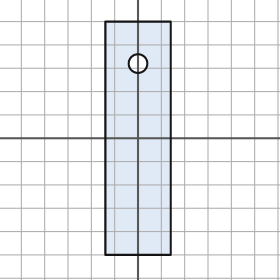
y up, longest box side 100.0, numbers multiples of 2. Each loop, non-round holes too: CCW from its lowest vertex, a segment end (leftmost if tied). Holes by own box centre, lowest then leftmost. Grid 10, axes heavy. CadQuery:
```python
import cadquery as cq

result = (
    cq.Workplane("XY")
    .moveTo(-14.0, -50.0)
    .lineTo(14.0, -50.0)
    .lineTo(14.0, 50.0)
    .lineTo(-14.0, 50.0)
    .close()
    .moveTo(0.0, 32.0)
    .circle(4.0)
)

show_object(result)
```